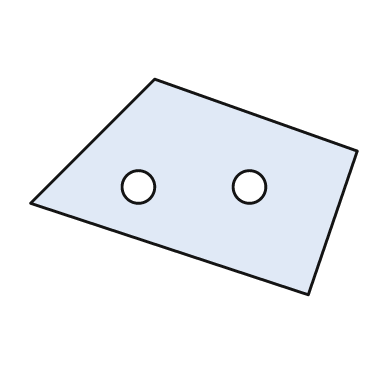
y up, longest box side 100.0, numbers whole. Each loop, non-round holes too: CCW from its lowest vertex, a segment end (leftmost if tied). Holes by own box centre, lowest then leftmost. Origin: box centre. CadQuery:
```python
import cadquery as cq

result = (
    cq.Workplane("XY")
    .moveTo(35.0, -33.0)
    .lineTo(50.0, 11.0)
    .lineTo(-12.0, 33.0)
    .lineTo(-50.0, -5.0)
    .close()
    .moveTo(-17.0, 0.0)
    .circle(5.0)
    .moveTo(17.0, 0.0)
    .circle(5.0)
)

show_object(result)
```